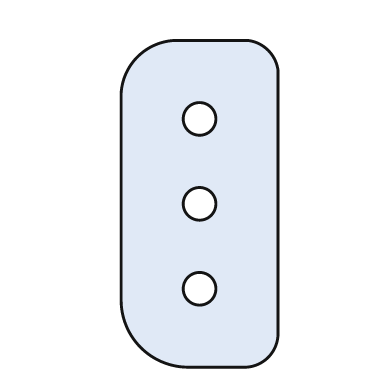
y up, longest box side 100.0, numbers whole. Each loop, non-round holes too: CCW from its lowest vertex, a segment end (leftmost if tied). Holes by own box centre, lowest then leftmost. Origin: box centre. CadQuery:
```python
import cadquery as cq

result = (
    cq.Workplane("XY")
    .moveTo(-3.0, -50.0)
    .lineTo(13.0, -50.0)
    .threePointArc((21.0, -47.0), (24.0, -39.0))
    .lineTo(24.0, 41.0)
    .threePointArc((21.0, 47.0), (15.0, 50.0))
    .lineTo(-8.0, 50.0)
    .threePointArc((-19.0, 45.0), (-24.0, 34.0))
    .lineTo(-24.0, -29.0)
    .threePointArc((-18.0, -44.0), (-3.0, -50.0))
    .close()
    .moveTo(0.0, -26.0)
    .circle(5.0)
    .moveTo(0.0, 0.0)
    .circle(5.0)
    .moveTo(0.0, 26.0)
    .circle(5.0)
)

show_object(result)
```